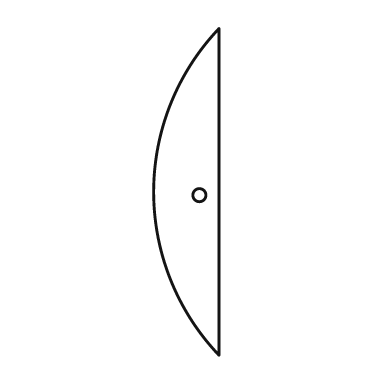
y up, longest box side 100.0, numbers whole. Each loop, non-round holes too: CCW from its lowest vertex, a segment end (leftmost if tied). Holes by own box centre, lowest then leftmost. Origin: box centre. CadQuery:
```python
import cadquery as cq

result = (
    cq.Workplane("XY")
    .moveTo(10.0, -50.0)
    .lineTo(10.0, 50.0)
    .threePointArc((-10.0, 0.0), (10.0, -50.0))
    .close()
    .moveTo(4.0, -1.0)
    .circle(2.0)
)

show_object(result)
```